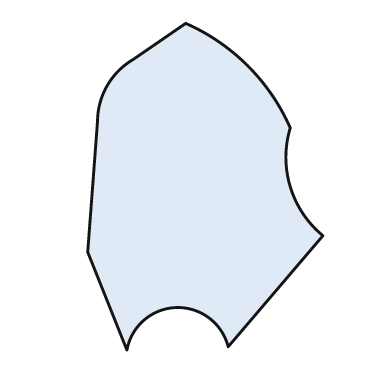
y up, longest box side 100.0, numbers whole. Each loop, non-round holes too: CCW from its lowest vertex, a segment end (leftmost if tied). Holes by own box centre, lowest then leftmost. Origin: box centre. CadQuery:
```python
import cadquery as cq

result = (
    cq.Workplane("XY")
    .moveTo(-24.0, -50.0)
    .threePointArc((-9.0, -37.0), (7.0, -49.0))
    .lineTo(36.0, -15.0)
    .threePointArc((26.0, 0.0), (26.0, 18.0))
    .threePointArc((13.0, 37.0), (-6.0, 50.0))
    .lineTo(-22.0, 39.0)
    .threePointArc((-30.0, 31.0), (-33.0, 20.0))
    .lineTo(-36.0, -20.0)
    .close()
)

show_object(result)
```